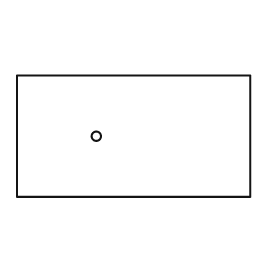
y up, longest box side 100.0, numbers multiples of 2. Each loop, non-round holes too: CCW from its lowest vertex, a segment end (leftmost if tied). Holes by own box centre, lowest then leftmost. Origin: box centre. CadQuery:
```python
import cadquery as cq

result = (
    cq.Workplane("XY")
    .moveTo(-50.0, -26.0)
    .lineTo(50.0, -26.0)
    .lineTo(50.0, 26.0)
    .lineTo(-50.0, 26.0)
    .close()
    .moveTo(-16.0, 0.0)
    .circle(2.0)
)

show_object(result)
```